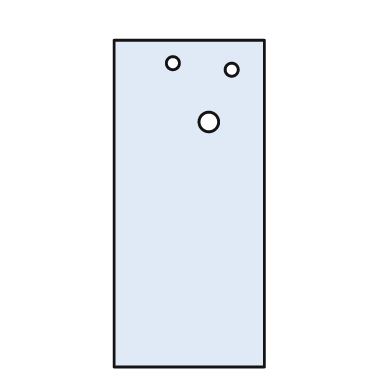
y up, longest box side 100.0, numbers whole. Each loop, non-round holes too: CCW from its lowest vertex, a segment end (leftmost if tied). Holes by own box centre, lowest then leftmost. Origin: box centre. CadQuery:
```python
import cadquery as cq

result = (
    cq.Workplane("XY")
    .moveTo(-23.0, -50.0)
    .lineTo(23.0, -50.0)
    .lineTo(23.0, 50.0)
    .lineTo(-23.0, 50.0)
    .close()
    .moveTo(6.0, 25.0)
    .circle(3.0)
    .moveTo(13.0, 41.0)
    .circle(2.0)
    .moveTo(-5.0, 43.0)
    .circle(2.0)
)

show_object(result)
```